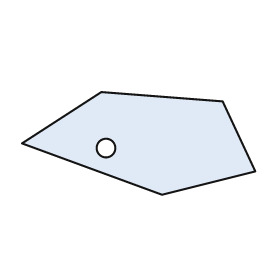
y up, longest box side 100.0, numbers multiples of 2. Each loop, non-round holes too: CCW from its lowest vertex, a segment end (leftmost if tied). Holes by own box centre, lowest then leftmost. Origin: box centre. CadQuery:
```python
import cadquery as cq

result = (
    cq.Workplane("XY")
    .moveTo(10.0, -22.0)
    .lineTo(50.0, -12.0)
    .lineTo(36.0, 18.0)
    .lineTo(-16.0, 22.0)
    .lineTo(-50.0, 0.0)
    .close()
    .moveTo(-14.0, -2.0)
    .circle(4.0)
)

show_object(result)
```